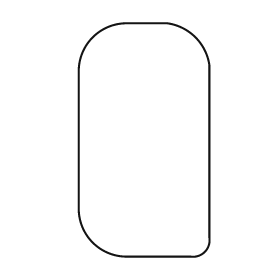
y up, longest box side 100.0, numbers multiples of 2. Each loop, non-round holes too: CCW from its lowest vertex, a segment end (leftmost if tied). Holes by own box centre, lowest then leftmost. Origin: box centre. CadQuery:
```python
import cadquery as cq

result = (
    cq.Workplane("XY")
    .moveTo(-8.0, -50.0)
    .lineTo(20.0, -50.0)
    .threePointArc((26.0, -48.0), (28.0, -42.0))
    .lineTo(28.0, 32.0)
    .threePointArc((22.0, 44.0), (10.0, 50.0))
    .lineTo(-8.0, 50.0)
    .threePointArc((-22.0, 44.0), (-28.0, 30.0))
    .lineTo(-28.0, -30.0)
    .threePointArc((-22.0, -44.0), (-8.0, -50.0))
    .close()
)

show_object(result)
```